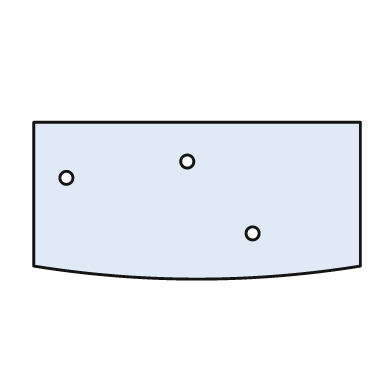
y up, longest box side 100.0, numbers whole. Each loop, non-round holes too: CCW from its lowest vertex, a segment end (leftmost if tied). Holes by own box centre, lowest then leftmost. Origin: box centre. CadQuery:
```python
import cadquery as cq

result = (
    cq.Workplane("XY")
    .moveTo(-50.0, -20.0)
    .threePointArc((0.0, -24.0), (50.0, -20.0))
    .lineTo(50.0, 24.0)
    .lineTo(-50.0, 24.0)
    .close()
    .moveTo(17.0, -10.0)
    .circle(2.0)
    .moveTo(-40.0, 7.0)
    .circle(2.0)
    .moveTo(-3.0, 12.0)
    .circle(2.0)
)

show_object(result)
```